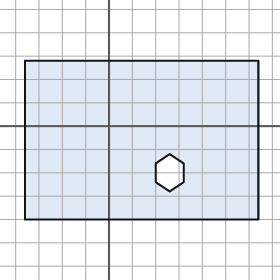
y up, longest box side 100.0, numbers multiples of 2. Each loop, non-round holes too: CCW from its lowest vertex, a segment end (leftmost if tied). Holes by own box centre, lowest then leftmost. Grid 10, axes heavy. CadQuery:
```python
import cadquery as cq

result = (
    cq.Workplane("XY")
    .moveTo(-36.0, -40.0)
    .lineTo(64.0, -40.0)
    .lineTo(64.0, 28.0)
    .lineTo(-36.0, 28.0)
    .close()
    .moveTo(26.0, -28.0)
    .lineTo(32.0, -24.0)
    .lineTo(32.0, -16.0)
    .lineTo(26.0, -12.0)
    .lineTo(20.0, -16.0)
    .lineTo(20.0, -24.0)
    .close()
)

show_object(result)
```